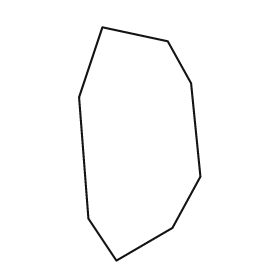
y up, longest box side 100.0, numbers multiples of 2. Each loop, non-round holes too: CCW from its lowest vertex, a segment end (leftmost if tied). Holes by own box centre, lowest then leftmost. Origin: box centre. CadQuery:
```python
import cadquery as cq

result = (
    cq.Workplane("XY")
    .moveTo(-10.0, -50.0)
    .lineTo(14.0, -36.0)
    .lineTo(26.0, -14.0)
    .lineTo(22.0, 26.0)
    .lineTo(12.0, 44.0)
    .lineTo(-16.0, 50.0)
    .lineTo(-26.0, 20.0)
    .lineTo(-22.0, -32.0)
    .close()
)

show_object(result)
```